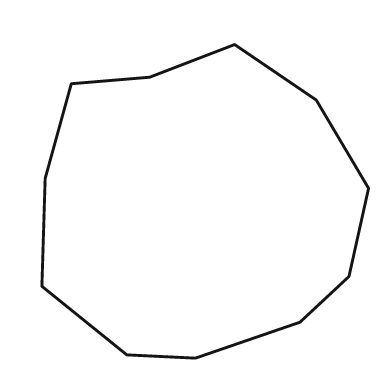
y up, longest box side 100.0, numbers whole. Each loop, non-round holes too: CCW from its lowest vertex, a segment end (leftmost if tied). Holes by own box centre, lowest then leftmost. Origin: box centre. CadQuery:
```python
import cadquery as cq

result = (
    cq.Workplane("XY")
    .moveTo(-3.0, -48.0)
    .lineTo(29.0, -37.0)
    .lineTo(44.0, -23.0)
    .lineTo(50.0, 4.0)
    .lineTo(34.0, 31.0)
    .lineTo(9.0, 48.0)
    .lineTo(-17.0, 38.0)
    .lineTo(-41.0, 36.0)
    .lineTo(-49.0, 7.0)
    .lineTo(-50.0, -26.0)
    .lineTo(-24.0, -47.0)
    .close()
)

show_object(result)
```